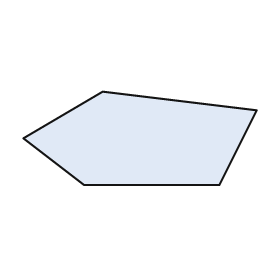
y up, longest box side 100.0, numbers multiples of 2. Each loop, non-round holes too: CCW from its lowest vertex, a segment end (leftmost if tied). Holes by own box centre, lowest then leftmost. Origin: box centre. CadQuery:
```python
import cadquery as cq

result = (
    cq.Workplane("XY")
    .moveTo(-24.0, -20.0)
    .lineTo(34.0, -20.0)
    .lineTo(50.0, 12.0)
    .lineTo(-16.0, 20.0)
    .lineTo(-50.0, 0.0)
    .close()
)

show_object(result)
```